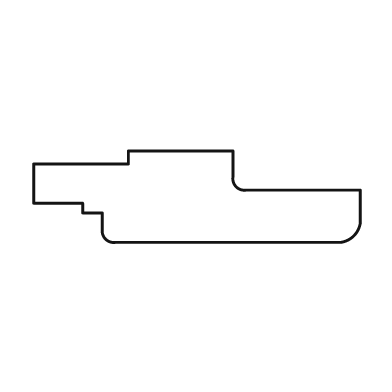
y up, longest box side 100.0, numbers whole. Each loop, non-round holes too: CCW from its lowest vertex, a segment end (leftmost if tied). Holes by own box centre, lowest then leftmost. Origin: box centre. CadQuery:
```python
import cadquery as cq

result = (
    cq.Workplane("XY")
    .moveTo(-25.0, -14.0)
    .lineTo(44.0, -14.0)
    .threePointArc((48.0, -12.0), (50.0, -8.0))
    .lineTo(50.0, 2.0)
    .lineTo(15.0, 2.0)
    .threePointArc((12.0, 3.0), (11.0, 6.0))
    .lineTo(11.0, 14.0)
    .lineTo(-21.0, 14.0)
    .lineTo(-21.0, 10.0)
    .lineTo(-50.0, 10.0)
    .lineTo(-50.0, -2.0)
    .lineTo(-35.0, -2.0)
    .lineTo(-35.0, -5.0)
    .lineTo(-29.0, -5.0)
    .lineTo(-29.0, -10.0)
    .threePointArc((-28.0, -13.0), (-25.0, -14.0))
    .close()
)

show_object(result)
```